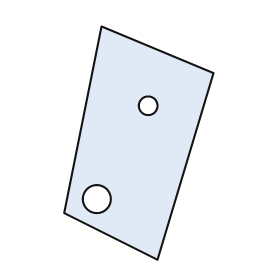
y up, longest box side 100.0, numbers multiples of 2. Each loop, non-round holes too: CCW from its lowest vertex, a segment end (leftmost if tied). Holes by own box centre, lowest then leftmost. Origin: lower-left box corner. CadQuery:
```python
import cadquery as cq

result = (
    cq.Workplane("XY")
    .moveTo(40.0, 0.0)
    .lineTo(64.0, 80.0)
    .lineTo(16.0, 100.0)
    .lineTo(0.0, 20.0)
    .close()
    .moveTo(14.0, 26.0)
    .circle(6.0)
    .moveTo(36.0, 66.0)
    .circle(4.0)
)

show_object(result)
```